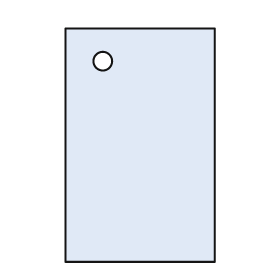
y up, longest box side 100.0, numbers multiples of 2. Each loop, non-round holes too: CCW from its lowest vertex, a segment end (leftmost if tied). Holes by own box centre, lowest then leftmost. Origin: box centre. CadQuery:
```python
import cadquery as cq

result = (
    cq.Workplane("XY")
    .moveTo(-32.0, -50.0)
    .lineTo(32.0, -50.0)
    .lineTo(32.0, 50.0)
    .lineTo(-32.0, 50.0)
    .close()
    .moveTo(-16.0, 36.0)
    .circle(4.0)
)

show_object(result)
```